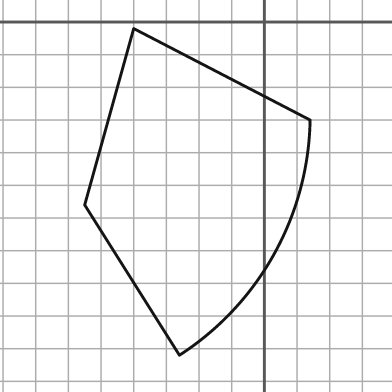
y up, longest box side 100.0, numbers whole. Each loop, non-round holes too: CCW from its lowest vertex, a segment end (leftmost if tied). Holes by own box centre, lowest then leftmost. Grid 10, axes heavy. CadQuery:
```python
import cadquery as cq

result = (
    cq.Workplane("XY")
    .moveTo(-26.0, -102.0)
    .threePointArc((3.0, -71.0), (14.0, -30.0))
    .lineTo(-40.0, -2.0)
    .lineTo(-55.0, -56.0)
    .close()
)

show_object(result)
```